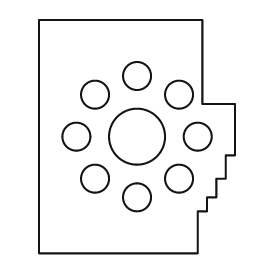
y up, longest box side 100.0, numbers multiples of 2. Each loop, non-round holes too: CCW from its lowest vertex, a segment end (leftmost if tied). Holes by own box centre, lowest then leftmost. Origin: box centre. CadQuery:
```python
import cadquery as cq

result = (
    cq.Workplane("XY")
    .moveTo(-42.0, -50.0)
    .lineTo(26.0, -50.0)
    .lineTo(26.0, -32.0)
    .lineTo(30.0, -32.0)
    .lineTo(30.0, -26.0)
    .lineTo(34.0, -26.0)
    .lineTo(34.0, -18.0)
    .lineTo(38.0, -18.0)
    .lineTo(38.0, -8.0)
    .lineTo(42.0, -8.0)
    .lineTo(42.0, 14.0)
    .lineTo(28.0, 14.0)
    .lineTo(28.0, 50.0)
    .lineTo(-42.0, 50.0)
    .close()
    .moveTo(0.0, -26.0)
    .circle(6.0)
    .moveTo(-18.0, -18.0)
    .circle(6.0)
    .moveTo(18.0, -18.0)
    .circle(6.0)
    .moveTo(-26.0, 0.0)
    .circle(6.0)
    .moveTo(0.0, 0.0)
    .circle(12.0)
    .moveTo(26.0, 0.0)
    .circle(6.0)
    .moveTo(-18.0, 18.0)
    .circle(6.0)
    .moveTo(18.0, 18.0)
    .circle(6.0)
    .moveTo(0.0, 26.0)
    .circle(6.0)
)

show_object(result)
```